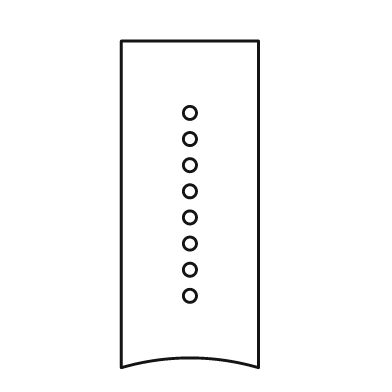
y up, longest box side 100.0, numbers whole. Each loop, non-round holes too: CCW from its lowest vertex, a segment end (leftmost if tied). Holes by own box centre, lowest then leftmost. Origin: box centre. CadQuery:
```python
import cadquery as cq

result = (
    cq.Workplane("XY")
    .moveTo(-21.0, -50.0)
    .threePointArc((0.0, -47.0), (21.0, -50.0))
    .lineTo(21.0, 50.0)
    .lineTo(-21.0, 50.0)
    .close()
    .moveTo(0.0, -28.0)
    .circle(2.0)
    .moveTo(0.0, -20.0)
    .circle(2.0)
    .moveTo(0.0, -12.0)
    .circle(2.0)
    .moveTo(0.0, -4.0)
    .circle(2.0)
    .moveTo(0.0, 4.0)
    .circle(2.0)
    .moveTo(0.0, 12.0)
    .circle(2.0)
    .moveTo(0.0, 20.0)
    .circle(2.0)
    .moveTo(0.0, 28.0)
    .circle(2.0)
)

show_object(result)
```